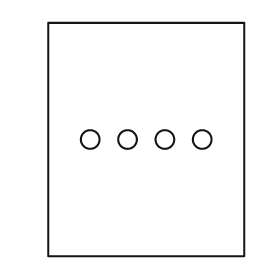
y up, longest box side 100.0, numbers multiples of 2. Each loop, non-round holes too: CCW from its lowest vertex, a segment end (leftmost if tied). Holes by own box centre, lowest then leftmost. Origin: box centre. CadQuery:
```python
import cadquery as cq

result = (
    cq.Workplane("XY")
    .moveTo(-42.0, -50.0)
    .lineTo(42.0, -50.0)
    .lineTo(42.0, 50.0)
    .lineTo(-42.0, 50.0)
    .close()
    .moveTo(-24.0, 0.0)
    .circle(4.0)
    .moveTo(-8.0, 0.0)
    .circle(4.0)
    .moveTo(8.0, 0.0)
    .circle(4.0)
    .moveTo(24.0, 0.0)
    .circle(4.0)
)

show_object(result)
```